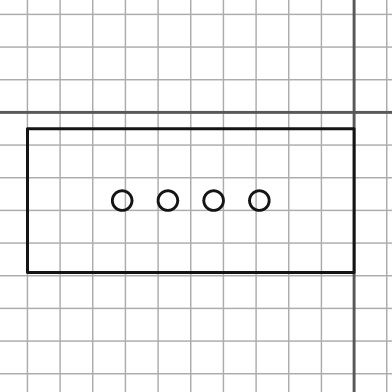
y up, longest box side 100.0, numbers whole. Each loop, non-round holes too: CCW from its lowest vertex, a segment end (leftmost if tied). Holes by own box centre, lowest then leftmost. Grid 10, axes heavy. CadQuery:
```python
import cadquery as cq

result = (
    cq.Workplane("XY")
    .moveTo(-100.0, -49.0)
    .lineTo(0.0, -49.0)
    .lineTo(0.0, -5.0)
    .lineTo(-100.0, -5.0)
    .close()
    .moveTo(-71.0, -27.0)
    .circle(3.0)
    .moveTo(-57.0, -27.0)
    .circle(3.0)
    .moveTo(-43.0, -27.0)
    .circle(3.0)
    .moveTo(-29.0, -27.0)
    .circle(3.0)
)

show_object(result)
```